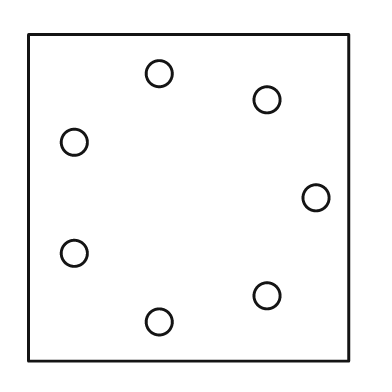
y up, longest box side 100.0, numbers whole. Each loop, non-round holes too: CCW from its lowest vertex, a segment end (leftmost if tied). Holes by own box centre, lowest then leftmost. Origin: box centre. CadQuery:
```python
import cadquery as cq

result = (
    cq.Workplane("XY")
    .moveTo(-49.0, -50.0)
    .lineTo(49.0, -50.0)
    .lineTo(49.0, 50.0)
    .lineTo(-49.0, 50.0)
    .close()
    .moveTo(-9.0, -38.0)
    .circle(4.0)
    .moveTo(24.0, -30.0)
    .circle(4.0)
    .moveTo(-35.0, -17.0)
    .circle(4.0)
    .moveTo(39.0, 0.0)
    .circle(4.0)
    .moveTo(-35.0, 17.0)
    .circle(4.0)
    .moveTo(24.0, 30.0)
    .circle(4.0)
    .moveTo(-9.0, 38.0)
    .circle(4.0)
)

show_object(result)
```